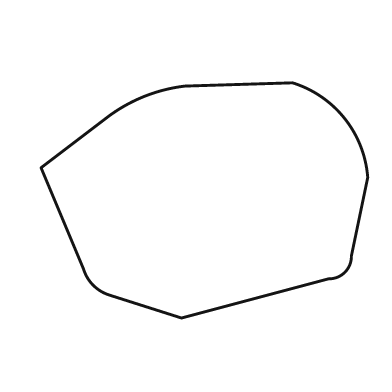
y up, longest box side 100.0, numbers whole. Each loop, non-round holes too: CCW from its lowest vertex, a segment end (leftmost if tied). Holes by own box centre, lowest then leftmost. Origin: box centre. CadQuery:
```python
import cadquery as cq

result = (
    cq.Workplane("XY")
    .moveTo(-7.0, -36.0)
    .lineTo(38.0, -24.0)
    .threePointArc((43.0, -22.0), (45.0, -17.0))
    .lineTo(50.0, 7.0)
    .threePointArc((43.0, 25.0), (27.0, 36.0))
    .lineTo(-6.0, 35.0)
    .threePointArc((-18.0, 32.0), (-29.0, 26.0))
    .lineTo(-50.0, 10.0)
    .lineTo(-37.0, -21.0)
    .threePointArc((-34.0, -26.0), (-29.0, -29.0))
    .close()
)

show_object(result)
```